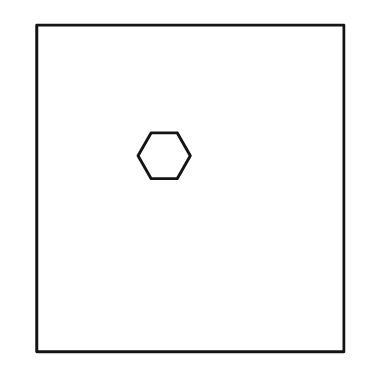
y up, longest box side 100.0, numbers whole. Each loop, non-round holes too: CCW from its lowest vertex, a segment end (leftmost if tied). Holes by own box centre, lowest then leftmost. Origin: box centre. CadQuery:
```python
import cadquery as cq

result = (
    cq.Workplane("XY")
    .moveTo(-47.0, -50.0)
    .lineTo(47.0, -50.0)
    .lineTo(47.0, 50.0)
    .lineTo(-47.0, 50.0)
    .close()
    .moveTo(-12.0, 3.0)
    .lineTo(-4.0, 3.0)
    .lineTo(0.0, 10.0)
    .lineTo(-4.0, 17.0)
    .lineTo(-12.0, 17.0)
    .lineTo(-16.0, 10.0)
    .close()
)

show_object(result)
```